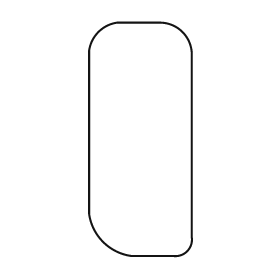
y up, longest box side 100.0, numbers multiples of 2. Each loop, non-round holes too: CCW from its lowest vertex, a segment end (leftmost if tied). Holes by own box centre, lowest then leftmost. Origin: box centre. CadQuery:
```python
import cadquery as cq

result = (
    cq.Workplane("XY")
    .moveTo(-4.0, -50.0)
    .lineTo(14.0, -50.0)
    .threePointArc((20.0, -48.0), (22.0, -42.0))
    .lineTo(22.0, 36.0)
    .threePointArc((18.0, 46.0), (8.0, 50.0))
    .lineTo(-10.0, 50.0)
    .threePointArc((-18.0, 46.0), (-22.0, 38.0))
    .lineTo(-22.0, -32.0)
    .threePointArc((-16.0, -44.0), (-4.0, -50.0))
    .close()
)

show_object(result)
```